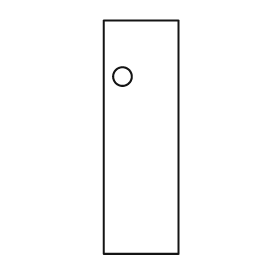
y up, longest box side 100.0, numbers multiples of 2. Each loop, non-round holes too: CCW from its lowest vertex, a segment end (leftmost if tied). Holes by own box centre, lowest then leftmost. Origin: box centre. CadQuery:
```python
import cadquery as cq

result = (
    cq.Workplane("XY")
    .moveTo(-16.0, -50.0)
    .lineTo(16.0, -50.0)
    .lineTo(16.0, 50.0)
    .lineTo(-16.0, 50.0)
    .close()
    .moveTo(-8.0, 26.0)
    .circle(4.0)
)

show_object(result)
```